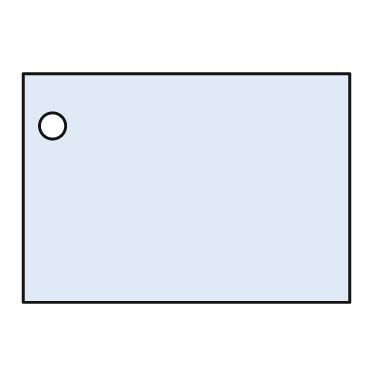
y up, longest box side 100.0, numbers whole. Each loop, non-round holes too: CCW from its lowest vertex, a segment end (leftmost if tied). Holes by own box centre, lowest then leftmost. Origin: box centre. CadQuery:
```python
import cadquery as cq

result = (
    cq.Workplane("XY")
    .moveTo(-50.0, -35.0)
    .lineTo(50.0, -35.0)
    .lineTo(50.0, 35.0)
    .lineTo(-50.0, 35.0)
    .close()
    .moveTo(-41.0, 19.0)
    .circle(4.0)
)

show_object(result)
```